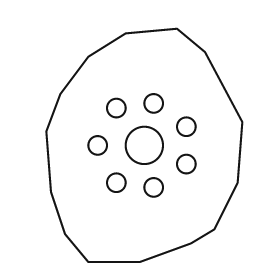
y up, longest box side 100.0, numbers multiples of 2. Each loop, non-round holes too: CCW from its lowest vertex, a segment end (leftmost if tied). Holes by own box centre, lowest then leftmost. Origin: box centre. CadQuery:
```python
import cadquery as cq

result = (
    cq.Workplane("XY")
    .moveTo(-24.0, -50.0)
    .lineTo(-2.0, -50.0)
    .lineTo(20.0, -42.0)
    .lineTo(30.0, -36.0)
    .lineTo(40.0, -16.0)
    .lineTo(42.0, 10.0)
    .lineTo(26.0, 40.0)
    .lineTo(14.0, 50.0)
    .lineTo(-8.0, 48.0)
    .lineTo(-24.0, 38.0)
    .lineTo(-36.0, 22.0)
    .lineTo(-42.0, 6.0)
    .lineTo(-40.0, -20.0)
    .lineTo(-34.0, -38.0)
    .close()
    .moveTo(4.0, -18.0)
    .circle(4.0)
    .moveTo(-12.0, -16.0)
    .circle(4.0)
    .moveTo(18.0, -8.0)
    .circle(4.0)
    .moveTo(-20.0, 0.0)
    .circle(4.0)
    .moveTo(0.0, 0.0)
    .circle(8.0)
    .moveTo(18.0, 8.0)
    .circle(4.0)
    .moveTo(-12.0, 16.0)
    .circle(4.0)
    .moveTo(4.0, 18.0)
    .circle(4.0)
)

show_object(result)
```